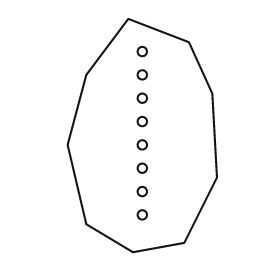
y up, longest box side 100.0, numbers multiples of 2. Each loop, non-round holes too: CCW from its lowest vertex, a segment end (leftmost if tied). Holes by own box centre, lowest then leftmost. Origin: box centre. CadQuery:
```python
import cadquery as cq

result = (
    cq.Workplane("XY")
    .moveTo(-4.0, -50.0)
    .lineTo(18.0, -46.0)
    .lineTo(32.0, -18.0)
    .lineTo(30.0, 18.0)
    .lineTo(20.0, 40.0)
    .lineTo(-6.0, 50.0)
    .lineTo(-24.0, 26.0)
    .lineTo(-32.0, -4.0)
    .lineTo(-24.0, -38.0)
    .close()
    .moveTo(0.0, -34.0)
    .circle(2.0)
    .moveTo(0.0, -24.0)
    .circle(2.0)
    .moveTo(0.0, -14.0)
    .circle(2.0)
    .moveTo(0.0, -4.0)
    .circle(2.0)
    .moveTo(0.0, 6.0)
    .circle(2.0)
    .moveTo(0.0, 16.0)
    .circle(2.0)
    .moveTo(0.0, 26.0)
    .circle(2.0)
    .moveTo(0.0, 36.0)
    .circle(2.0)
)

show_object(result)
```